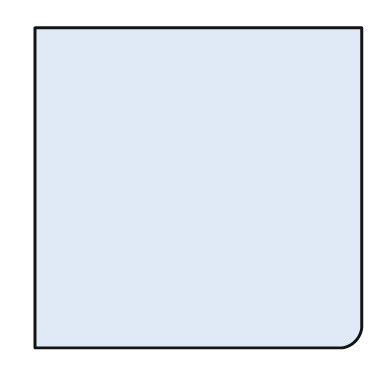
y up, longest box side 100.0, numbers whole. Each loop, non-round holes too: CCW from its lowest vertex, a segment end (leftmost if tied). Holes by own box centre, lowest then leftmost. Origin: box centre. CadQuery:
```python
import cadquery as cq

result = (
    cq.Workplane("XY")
    .moveTo(-50.0, -49.0)
    .lineTo(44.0, -49.0)
    .threePointArc((48.0, -47.0), (50.0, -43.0))
    .lineTo(50.0, 49.0)
    .lineTo(-50.0, 49.0)
    .close()
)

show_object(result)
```